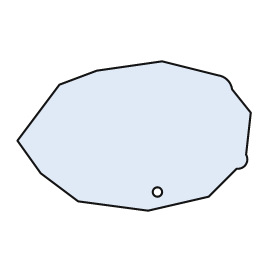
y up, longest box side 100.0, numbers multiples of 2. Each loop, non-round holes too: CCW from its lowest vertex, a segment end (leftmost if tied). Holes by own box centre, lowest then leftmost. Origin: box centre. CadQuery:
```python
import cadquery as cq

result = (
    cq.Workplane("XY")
    .moveTo(6.0, -32.0)
    .lineTo(32.0, -26.0)
    .lineTo(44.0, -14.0)
    .threePointArc((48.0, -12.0), (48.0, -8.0))
    .lineTo(50.0, 10.0)
    .lineTo(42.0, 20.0)
    .threePointArc((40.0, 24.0), (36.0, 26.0))
    .lineTo(12.0, 32.0)
    .lineTo(-16.0, 28.0)
    .lineTo(-32.0, 22.0)
    .lineTo(-50.0, -2.0)
    .lineTo(-40.0, -16.0)
    .lineTo(-24.0, -28.0)
    .close()
    .moveTo(10.0, -24.0)
    .circle(2.0)
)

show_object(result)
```